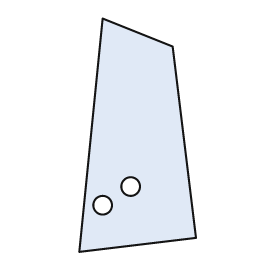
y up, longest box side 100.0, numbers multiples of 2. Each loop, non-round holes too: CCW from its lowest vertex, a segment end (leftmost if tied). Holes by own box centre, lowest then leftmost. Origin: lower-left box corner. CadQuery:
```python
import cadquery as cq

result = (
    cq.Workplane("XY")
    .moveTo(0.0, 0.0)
    .lineTo(50.0, 6.0)
    .lineTo(40.0, 88.0)
    .lineTo(10.0, 100.0)
    .close()
    .moveTo(10.0, 20.0)
    .circle(4.0)
    .moveTo(22.0, 28.0)
    .circle(4.0)
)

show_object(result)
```